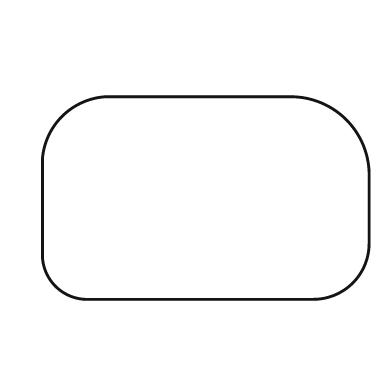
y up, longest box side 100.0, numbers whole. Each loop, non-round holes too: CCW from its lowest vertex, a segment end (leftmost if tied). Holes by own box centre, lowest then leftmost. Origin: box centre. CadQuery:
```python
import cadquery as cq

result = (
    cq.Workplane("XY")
    .moveTo(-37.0, -31.0)
    .lineTo(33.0, -31.0)
    .threePointArc((45.0, -26.0), (50.0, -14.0))
    .lineTo(50.0, 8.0)
    .threePointArc((43.0, 24.0), (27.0, 31.0))
    .lineTo(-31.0, 31.0)
    .threePointArc((-44.0, 25.0), (-50.0, 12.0))
    .lineTo(-50.0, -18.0)
    .threePointArc((-46.0, -27.0), (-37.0, -31.0))
    .close()
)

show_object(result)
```